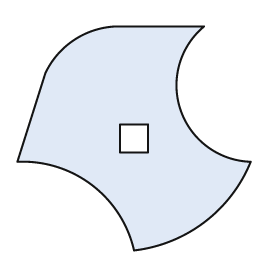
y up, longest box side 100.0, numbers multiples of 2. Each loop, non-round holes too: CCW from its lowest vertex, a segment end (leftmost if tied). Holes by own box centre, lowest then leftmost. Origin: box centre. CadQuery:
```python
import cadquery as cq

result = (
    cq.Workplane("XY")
    .moveTo(0.0, -48.0)
    .threePointArc((30.0, -36.0), (50.0, -10.0))
    .threePointArc((20.0, 12.0), (30.0, 48.0))
    .lineTo(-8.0, 48.0)
    .threePointArc((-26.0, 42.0), (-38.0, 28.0))
    .lineTo(-50.0, -10.0)
    .threePointArc((-18.0, -20.0), (0.0, -48.0))
    .close()
    .moveTo(-6.0, -6.0)
    .lineTo(6.0, -6.0)
    .lineTo(6.0, 6.0)
    .lineTo(-6.0, 6.0)
    .close()
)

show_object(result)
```